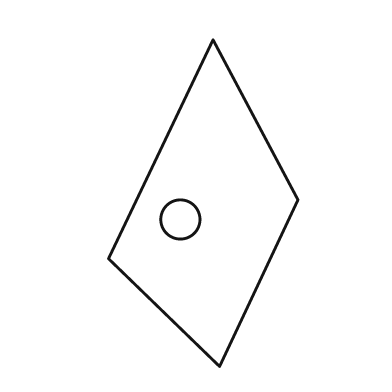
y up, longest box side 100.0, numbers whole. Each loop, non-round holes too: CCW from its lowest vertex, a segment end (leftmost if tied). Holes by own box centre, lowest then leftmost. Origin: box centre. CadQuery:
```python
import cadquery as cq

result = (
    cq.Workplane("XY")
    .moveTo(5.0, -50.0)
    .lineTo(29.0, 1.0)
    .lineTo(3.0, 50.0)
    .lineTo(-29.0, -17.0)
    .close()
    .moveTo(-7.0, -5.0)
    .circle(6.0)
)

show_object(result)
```